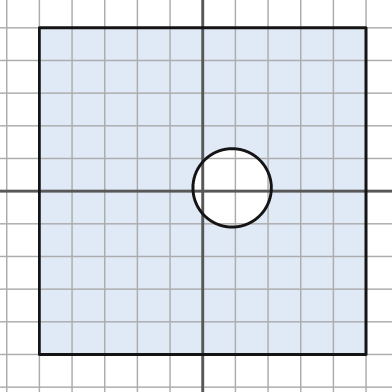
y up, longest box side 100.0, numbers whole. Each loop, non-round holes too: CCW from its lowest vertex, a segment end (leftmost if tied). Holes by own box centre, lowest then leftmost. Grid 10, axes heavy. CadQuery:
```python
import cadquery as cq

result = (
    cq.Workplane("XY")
    .moveTo(-50.0, -50.0)
    .lineTo(50.0, -50.0)
    .lineTo(50.0, 50.0)
    .lineTo(-50.0, 50.0)
    .close()
    .moveTo(9.0, 1.0)
    .circle(12.0)
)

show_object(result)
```